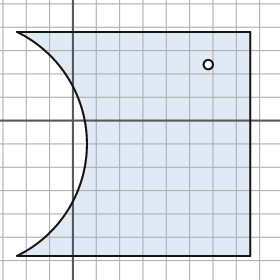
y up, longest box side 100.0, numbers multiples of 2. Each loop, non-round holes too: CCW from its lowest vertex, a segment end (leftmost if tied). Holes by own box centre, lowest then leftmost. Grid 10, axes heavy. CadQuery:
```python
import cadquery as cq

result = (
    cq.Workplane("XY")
    .moveTo(-24.0, -58.0)
    .lineTo(76.0, -58.0)
    .lineTo(76.0, 38.0)
    .lineTo(-24.0, 38.0)
    .threePointArc((6.0, -10.0), (-24.0, -58.0))
    .close()
    .moveTo(58.0, 24.0)
    .circle(2.0)
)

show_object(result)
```